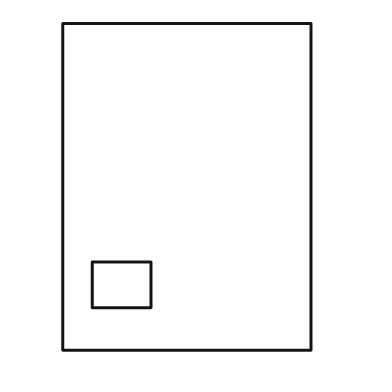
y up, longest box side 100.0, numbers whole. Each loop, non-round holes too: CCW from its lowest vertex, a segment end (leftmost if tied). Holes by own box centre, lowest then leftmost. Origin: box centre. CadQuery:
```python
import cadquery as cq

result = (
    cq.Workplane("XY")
    .moveTo(-38.0, -50.0)
    .lineTo(38.0, -50.0)
    .lineTo(38.0, 50.0)
    .lineTo(-38.0, 50.0)
    .close()
    .moveTo(-29.0, -37.0)
    .lineTo(-11.0, -37.0)
    .lineTo(-11.0, -23.0)
    .lineTo(-29.0, -23.0)
    .close()
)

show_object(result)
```